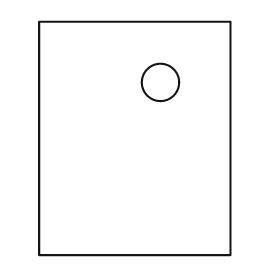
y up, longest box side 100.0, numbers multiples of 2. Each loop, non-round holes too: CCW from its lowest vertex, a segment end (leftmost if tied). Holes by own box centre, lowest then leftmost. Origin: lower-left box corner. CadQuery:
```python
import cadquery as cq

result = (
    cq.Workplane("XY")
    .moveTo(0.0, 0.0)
    .lineTo(82.0, 0.0)
    .lineTo(82.0, 100.0)
    .lineTo(0.0, 100.0)
    .close()
    .moveTo(52.0, 74.0)
    .circle(8.0)
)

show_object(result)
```